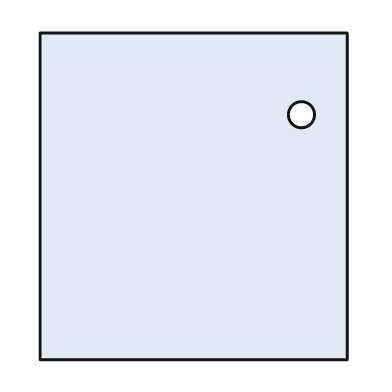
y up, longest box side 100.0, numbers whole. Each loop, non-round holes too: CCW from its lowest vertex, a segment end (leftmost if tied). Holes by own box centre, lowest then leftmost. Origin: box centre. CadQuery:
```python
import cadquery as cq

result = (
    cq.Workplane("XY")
    .moveTo(-47.0, -50.0)
    .lineTo(47.0, -50.0)
    .lineTo(47.0, 50.0)
    .lineTo(-47.0, 50.0)
    .close()
    .moveTo(33.0, 25.0)
    .circle(4.0)
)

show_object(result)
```